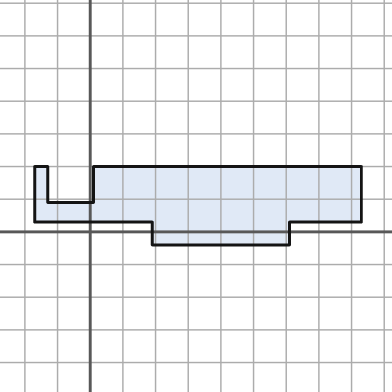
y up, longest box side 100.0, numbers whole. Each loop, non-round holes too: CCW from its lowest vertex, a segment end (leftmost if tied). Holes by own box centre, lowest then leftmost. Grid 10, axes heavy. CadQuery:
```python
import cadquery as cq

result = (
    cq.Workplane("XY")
    .moveTo(19.0, -4.0)
    .lineTo(61.0, -4.0)
    .lineTo(61.0, 3.0)
    .lineTo(83.0, 3.0)
    .lineTo(83.0, 20.0)
    .lineTo(1.0, 20.0)
    .lineTo(1.0, 9.0)
    .lineTo(-13.0, 9.0)
    .lineTo(-13.0, 20.0)
    .lineTo(-17.0, 20.0)
    .lineTo(-17.0, 3.0)
    .lineTo(19.0, 3.0)
    .close()
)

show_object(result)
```